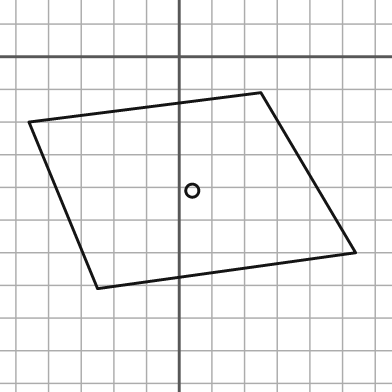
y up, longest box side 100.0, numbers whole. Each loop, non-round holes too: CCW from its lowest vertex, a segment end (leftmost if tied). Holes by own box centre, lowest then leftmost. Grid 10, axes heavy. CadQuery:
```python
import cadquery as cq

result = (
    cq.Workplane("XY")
    .moveTo(-25.0, -71.0)
    .lineTo(54.0, -60.0)
    .lineTo(25.0, -11.0)
    .lineTo(-46.0, -20.0)
    .close()
    .moveTo(4.0, -41.0)
    .circle(2.0)
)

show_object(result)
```